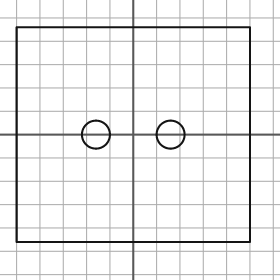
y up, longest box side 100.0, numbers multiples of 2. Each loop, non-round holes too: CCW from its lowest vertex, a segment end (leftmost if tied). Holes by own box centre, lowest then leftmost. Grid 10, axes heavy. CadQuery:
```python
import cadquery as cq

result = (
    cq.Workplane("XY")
    .moveTo(-50.0, -46.0)
    .lineTo(50.0, -46.0)
    .lineTo(50.0, 46.0)
    .lineTo(-50.0, 46.0)
    .close()
    .moveTo(-16.0, 0.0)
    .circle(6.0)
    .moveTo(16.0, 0.0)
    .circle(6.0)
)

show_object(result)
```